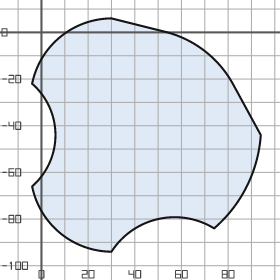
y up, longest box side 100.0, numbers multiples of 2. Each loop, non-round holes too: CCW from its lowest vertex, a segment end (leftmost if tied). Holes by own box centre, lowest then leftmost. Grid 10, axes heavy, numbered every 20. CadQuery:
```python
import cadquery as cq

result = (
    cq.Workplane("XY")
    .moveTo(30.0, -94.0)
    .threePointArc((50.0, -80.0), (74.0, -84.0))
    .threePointArc((88.0, -66.0), (94.0, -44.0))
    .lineTo(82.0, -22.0)
    .threePointArc((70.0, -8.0), (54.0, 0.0))
    .lineTo(30.0, 6.0)
    .threePointArc((8.0, -2.0), (-4.0, -22.0))
    .threePointArc((6.0, -44.0), (-4.0, -66.0))
    .threePointArc((8.0, -86.0), (30.0, -94.0))
    .close()
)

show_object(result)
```